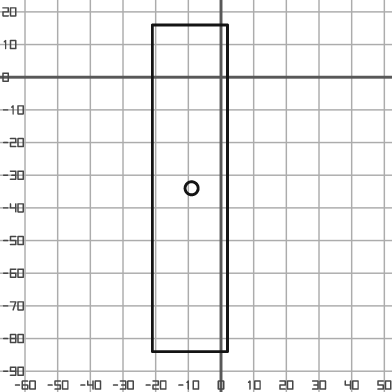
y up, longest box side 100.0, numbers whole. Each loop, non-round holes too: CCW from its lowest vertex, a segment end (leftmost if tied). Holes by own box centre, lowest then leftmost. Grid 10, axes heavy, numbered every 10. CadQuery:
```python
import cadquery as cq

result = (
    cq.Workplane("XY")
    .moveTo(-21.0, -84.0)
    .lineTo(2.0, -84.0)
    .lineTo(2.0, 16.0)
    .lineTo(-21.0, 16.0)
    .close()
    .moveTo(-9.0, -34.0)
    .circle(2.0)
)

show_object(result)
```